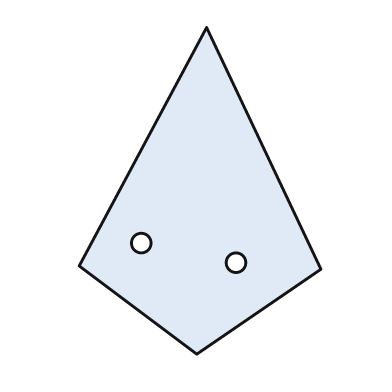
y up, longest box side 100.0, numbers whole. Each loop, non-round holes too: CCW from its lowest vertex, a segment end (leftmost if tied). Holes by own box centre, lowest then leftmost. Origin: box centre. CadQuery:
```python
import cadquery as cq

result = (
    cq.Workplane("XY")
    .moveTo(-1.0, -50.0)
    .lineTo(37.0, -24.0)
    .lineTo(2.0, 50.0)
    .lineTo(-37.0, -23.0)
    .close()
    .moveTo(11.0, -22.0)
    .circle(3.0)
    .moveTo(-18.0, -16.0)
    .circle(3.0)
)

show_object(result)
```